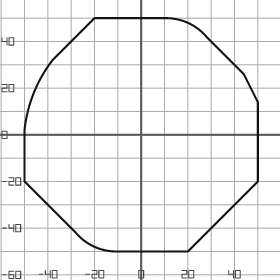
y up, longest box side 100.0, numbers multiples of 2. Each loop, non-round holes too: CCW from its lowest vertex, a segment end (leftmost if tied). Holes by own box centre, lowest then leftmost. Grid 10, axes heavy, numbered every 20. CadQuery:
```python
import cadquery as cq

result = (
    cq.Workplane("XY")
    .moveTo(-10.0, -50.0)
    .lineTo(20.0, -50.0)
    .lineTo(50.0, -20.0)
    .lineTo(50.0, 14.0)
    .lineTo(44.0, 26.0)
    .lineTo(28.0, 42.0)
    .threePointArc((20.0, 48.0), (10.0, 50.0))
    .lineTo(-20.0, 50.0)
    .lineTo(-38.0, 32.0)
    .threePointArc((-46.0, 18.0), (-50.0, 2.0))
    .lineTo(-50.0, -20.0)
    .lineTo(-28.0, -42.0)
    .threePointArc((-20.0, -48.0), (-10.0, -50.0))
    .close()
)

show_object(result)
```